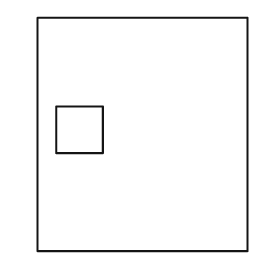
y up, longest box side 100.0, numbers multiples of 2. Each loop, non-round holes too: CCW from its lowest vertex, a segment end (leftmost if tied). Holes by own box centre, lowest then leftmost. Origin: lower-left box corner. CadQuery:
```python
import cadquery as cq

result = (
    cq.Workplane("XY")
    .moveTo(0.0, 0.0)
    .lineTo(90.0, 0.0)
    .lineTo(90.0, 100.0)
    .lineTo(0.0, 100.0)
    .close()
    .moveTo(8.0, 42.0)
    .lineTo(28.0, 42.0)
    .lineTo(28.0, 62.0)
    .lineTo(8.0, 62.0)
    .close()
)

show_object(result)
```